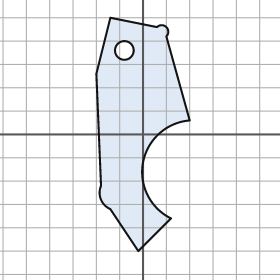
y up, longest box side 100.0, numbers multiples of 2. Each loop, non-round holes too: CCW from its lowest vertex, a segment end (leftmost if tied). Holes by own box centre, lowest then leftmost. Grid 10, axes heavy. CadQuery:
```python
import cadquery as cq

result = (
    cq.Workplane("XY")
    .moveTo(-2.0, -50.0)
    .lineTo(12.0, -36.0)
    .threePointArc((0.0, -12.0), (20.0, 6.0))
    .lineTo(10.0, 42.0)
    .threePointArc((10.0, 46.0), (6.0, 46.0))
    .lineTo(-14.0, 50.0)
    .lineTo(-20.0, 26.0)
    .lineTo(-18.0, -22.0)
    .threePointArc((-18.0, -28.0), (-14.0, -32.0))
    .close()
    .moveTo(-8.0, 36.0)
    .circle(4.0)
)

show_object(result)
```